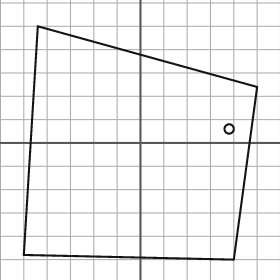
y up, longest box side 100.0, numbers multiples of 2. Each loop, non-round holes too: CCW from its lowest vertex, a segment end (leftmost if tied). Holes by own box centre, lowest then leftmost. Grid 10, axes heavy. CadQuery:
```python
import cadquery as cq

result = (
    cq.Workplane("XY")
    .moveTo(40.0, -50.0)
    .lineTo(50.0, 24.0)
    .lineTo(-44.0, 50.0)
    .lineTo(-50.0, -48.0)
    .close()
    .moveTo(38.0, 6.0)
    .circle(2.0)
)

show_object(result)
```